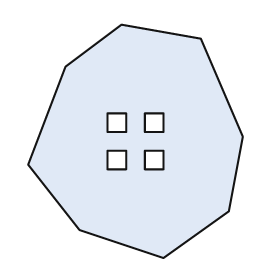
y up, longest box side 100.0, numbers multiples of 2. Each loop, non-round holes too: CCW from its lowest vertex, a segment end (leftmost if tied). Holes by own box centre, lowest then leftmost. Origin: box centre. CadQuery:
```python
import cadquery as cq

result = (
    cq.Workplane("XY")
    .moveTo(12.0, -50.0)
    .lineTo(40.0, -30.0)
    .lineTo(46.0, 2.0)
    .lineTo(28.0, 44.0)
    .lineTo(-6.0, 50.0)
    .lineTo(-30.0, 32.0)
    .lineTo(-46.0, -10.0)
    .lineTo(-24.0, -38.0)
    .close()
    .moveTo(-12.0, -12.0)
    .lineTo(-4.0, -12.0)
    .lineTo(-4.0, -4.0)
    .lineTo(-12.0, -4.0)
    .close()
    .moveTo(4.0, -12.0)
    .lineTo(12.0, -12.0)
    .lineTo(12.0, -4.0)
    .lineTo(4.0, -4.0)
    .close()
    .moveTo(-12.0, 4.0)
    .lineTo(-4.0, 4.0)
    .lineTo(-4.0, 12.0)
    .lineTo(-12.0, 12.0)
    .close()
    .moveTo(4.0, 4.0)
    .lineTo(12.0, 4.0)
    .lineTo(12.0, 12.0)
    .lineTo(4.0, 12.0)
    .close()
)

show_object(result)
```